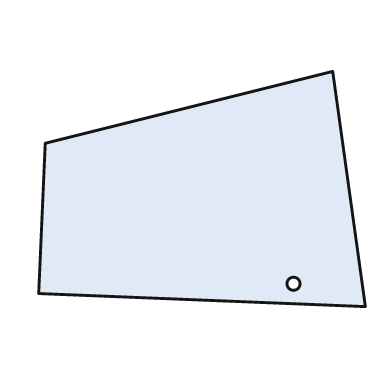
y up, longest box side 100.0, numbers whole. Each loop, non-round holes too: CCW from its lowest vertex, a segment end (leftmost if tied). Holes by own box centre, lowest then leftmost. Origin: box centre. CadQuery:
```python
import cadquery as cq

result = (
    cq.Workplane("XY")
    .moveTo(50.0, -36.0)
    .lineTo(40.0, 36.0)
    .lineTo(-48.0, 14.0)
    .lineTo(-50.0, -32.0)
    .close()
    .moveTo(28.0, -29.0)
    .circle(2.0)
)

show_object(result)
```